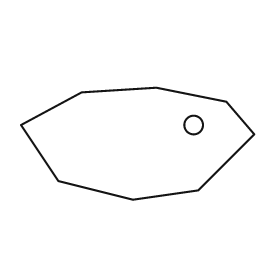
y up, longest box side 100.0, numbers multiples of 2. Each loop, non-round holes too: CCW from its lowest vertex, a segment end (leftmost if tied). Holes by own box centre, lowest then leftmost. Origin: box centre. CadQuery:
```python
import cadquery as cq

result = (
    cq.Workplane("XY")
    .moveTo(-2.0, -24.0)
    .lineTo(26.0, -20.0)
    .lineTo(50.0, 4.0)
    .lineTo(38.0, 18.0)
    .lineTo(8.0, 24.0)
    .lineTo(-24.0, 22.0)
    .lineTo(-50.0, 8.0)
    .lineTo(-34.0, -16.0)
    .close()
    .moveTo(24.0, 8.0)
    .circle(4.0)
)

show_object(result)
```